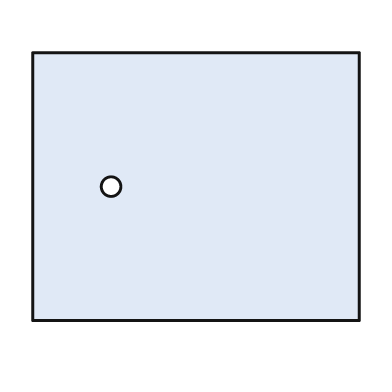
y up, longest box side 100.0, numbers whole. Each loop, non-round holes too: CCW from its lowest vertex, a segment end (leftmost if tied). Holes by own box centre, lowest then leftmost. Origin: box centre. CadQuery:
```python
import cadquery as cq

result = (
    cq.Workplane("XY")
    .moveTo(-50.0, -41.0)
    .lineTo(50.0, -41.0)
    .lineTo(50.0, 41.0)
    .lineTo(-50.0, 41.0)
    .close()
    .moveTo(-26.0, 0.0)
    .circle(3.0)
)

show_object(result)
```